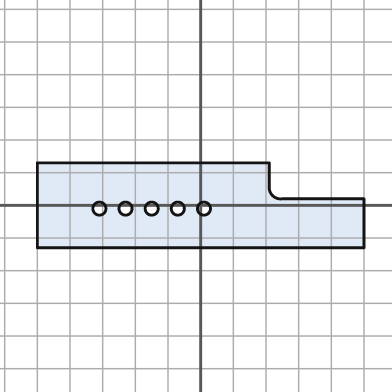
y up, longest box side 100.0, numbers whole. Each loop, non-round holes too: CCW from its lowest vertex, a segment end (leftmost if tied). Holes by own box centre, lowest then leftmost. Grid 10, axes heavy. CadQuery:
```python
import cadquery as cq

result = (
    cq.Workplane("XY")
    .moveTo(-50.0, -13.0)
    .lineTo(50.0, -13.0)
    .lineTo(50.0, 2.0)
    .lineTo(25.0, 2.0)
    .threePointArc((22.0, 3.0), (21.0, 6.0))
    .lineTo(21.0, 13.0)
    .lineTo(-50.0, 13.0)
    .close()
    .moveTo(-31.0, -1.0)
    .circle(2.0)
    .moveTo(-23.0, -1.0)
    .circle(2.0)
    .moveTo(-15.0, -1.0)
    .circle(2.0)
    .moveTo(-7.0, -1.0)
    .circle(2.0)
    .moveTo(1.0, -1.0)
    .circle(2.0)
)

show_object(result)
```